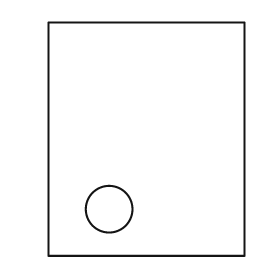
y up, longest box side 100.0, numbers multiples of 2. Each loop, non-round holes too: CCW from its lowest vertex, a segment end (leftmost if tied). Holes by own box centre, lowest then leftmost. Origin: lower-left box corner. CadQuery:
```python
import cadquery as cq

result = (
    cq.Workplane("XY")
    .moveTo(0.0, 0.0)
    .lineTo(84.0, 0.0)
    .lineTo(84.0, 100.0)
    .lineTo(0.0, 100.0)
    .close()
    .moveTo(26.0, 20.0)
    .circle(10.0)
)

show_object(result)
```